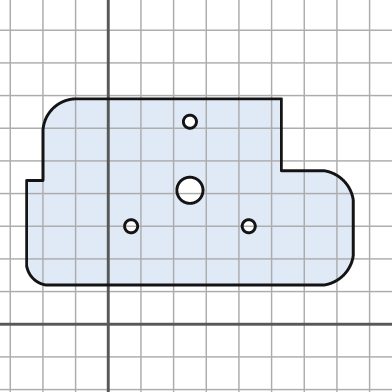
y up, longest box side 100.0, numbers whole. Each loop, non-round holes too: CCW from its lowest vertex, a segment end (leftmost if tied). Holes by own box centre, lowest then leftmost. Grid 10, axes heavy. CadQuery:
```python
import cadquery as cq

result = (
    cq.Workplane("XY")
    .moveTo(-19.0, 12.0)
    .lineTo(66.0, 12.0)
    .threePointArc((72.0, 15.0), (75.0, 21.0))
    .lineTo(75.0, 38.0)
    .threePointArc((72.0, 44.0), (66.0, 47.0))
    .lineTo(53.0, 47.0)
    .lineTo(53.0, 69.0)
    .lineTo(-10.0, 69.0)
    .threePointArc((-17.0, 66.0), (-20.0, 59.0))
    .lineTo(-20.0, 44.0)
    .lineTo(-25.0, 44.0)
    .lineTo(-25.0, 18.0)
    .threePointArc((-23.0, 14.0), (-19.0, 12.0))
    .close()
    .moveTo(7.0, 30.0)
    .circle(2.0)
    .moveTo(43.0, 30.0)
    .circle(2.0)
    .moveTo(25.0, 41.0)
    .circle(4.0)
    .moveTo(25.0, 62.0)
    .circle(2.0)
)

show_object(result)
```